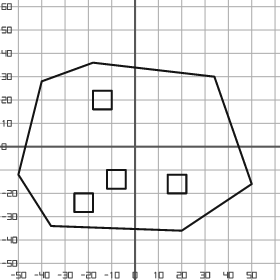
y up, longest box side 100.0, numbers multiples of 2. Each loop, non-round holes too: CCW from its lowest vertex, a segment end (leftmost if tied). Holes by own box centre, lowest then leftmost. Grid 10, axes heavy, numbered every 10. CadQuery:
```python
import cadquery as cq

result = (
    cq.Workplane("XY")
    .moveTo(20.0, -36.0)
    .lineTo(50.0, -16.0)
    .lineTo(34.0, 30.0)
    .lineTo(-18.0, 36.0)
    .lineTo(-40.0, 28.0)
    .lineTo(-50.0, -12.0)
    .lineTo(-36.0, -34.0)
    .close()
    .moveTo(-26.0, -28.0)
    .lineTo(-18.0, -28.0)
    .lineTo(-18.0, -20.0)
    .lineTo(-26.0, -20.0)
    .close()
    .moveTo(14.0, -20.0)
    .lineTo(22.0, -20.0)
    .lineTo(22.0, -12.0)
    .lineTo(14.0, -12.0)
    .close()
    .moveTo(-12.0, -18.0)
    .lineTo(-4.0, -18.0)
    .lineTo(-4.0, -10.0)
    .lineTo(-12.0, -10.0)
    .close()
    .moveTo(-18.0, 16.0)
    .lineTo(-10.0, 16.0)
    .lineTo(-10.0, 24.0)
    .lineTo(-18.0, 24.0)
    .close()
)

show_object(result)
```